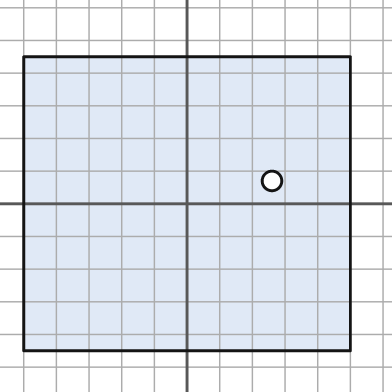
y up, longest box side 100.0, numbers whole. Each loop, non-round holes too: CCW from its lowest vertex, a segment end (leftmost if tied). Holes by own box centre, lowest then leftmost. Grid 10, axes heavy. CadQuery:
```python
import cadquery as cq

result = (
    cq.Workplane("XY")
    .moveTo(-50.0, -45.0)
    .lineTo(50.0, -45.0)
    .lineTo(50.0, 45.0)
    .lineTo(-50.0, 45.0)
    .close()
    .moveTo(26.0, 7.0)
    .circle(3.0)
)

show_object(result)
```